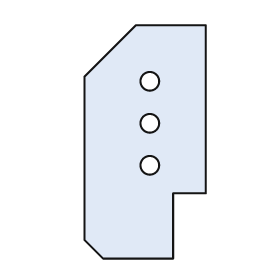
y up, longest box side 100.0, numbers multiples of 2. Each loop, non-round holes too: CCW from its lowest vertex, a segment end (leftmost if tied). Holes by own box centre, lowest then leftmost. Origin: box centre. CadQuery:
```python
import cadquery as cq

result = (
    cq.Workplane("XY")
    .moveTo(-18.0, -50.0)
    .lineTo(12.0, -50.0)
    .lineTo(12.0, -22.0)
    .lineTo(26.0, -22.0)
    .lineTo(26.0, 50.0)
    .lineTo(-4.0, 50.0)
    .lineTo(-26.0, 28.0)
    .lineTo(-26.0, -42.0)
    .close()
    .moveTo(2.0, -10.0)
    .circle(4.0)
    .moveTo(2.0, 8.0)
    .circle(4.0)
    .moveTo(2.0, 26.0)
    .circle(4.0)
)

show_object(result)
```